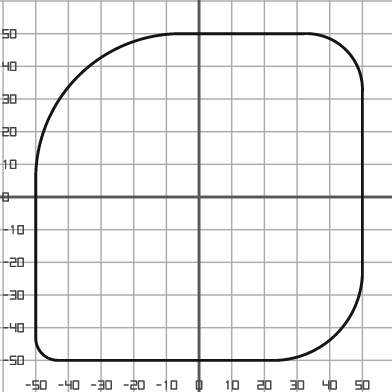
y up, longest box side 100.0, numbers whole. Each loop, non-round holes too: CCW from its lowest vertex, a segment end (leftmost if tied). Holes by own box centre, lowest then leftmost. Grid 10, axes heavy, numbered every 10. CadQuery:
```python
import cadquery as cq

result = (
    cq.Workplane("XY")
    .moveTo(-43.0, -50.0)
    .lineTo(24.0, -50.0)
    .threePointArc((42.0, -42.0), (50.0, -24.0))
    .lineTo(50.0, 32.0)
    .threePointArc((45.0, 45.0), (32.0, 50.0))
    .lineTo(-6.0, 50.0)
    .threePointArc((-37.0, 37.0), (-50.0, 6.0))
    .lineTo(-50.0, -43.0)
    .threePointArc((-48.0, -48.0), (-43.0, -50.0))
    .close()
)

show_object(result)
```